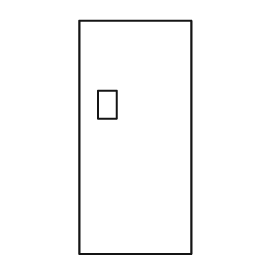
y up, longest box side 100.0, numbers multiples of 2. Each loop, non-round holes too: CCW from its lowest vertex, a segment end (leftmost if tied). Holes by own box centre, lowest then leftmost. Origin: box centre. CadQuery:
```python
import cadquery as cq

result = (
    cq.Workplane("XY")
    .moveTo(-24.0, -50.0)
    .lineTo(24.0, -50.0)
    .lineTo(24.0, 50.0)
    .lineTo(-24.0, 50.0)
    .close()
    .moveTo(-16.0, 8.0)
    .lineTo(-8.0, 8.0)
    .lineTo(-8.0, 20.0)
    .lineTo(-16.0, 20.0)
    .close()
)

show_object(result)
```